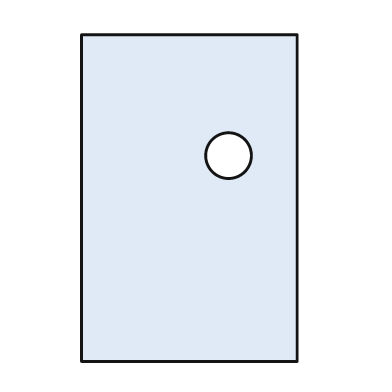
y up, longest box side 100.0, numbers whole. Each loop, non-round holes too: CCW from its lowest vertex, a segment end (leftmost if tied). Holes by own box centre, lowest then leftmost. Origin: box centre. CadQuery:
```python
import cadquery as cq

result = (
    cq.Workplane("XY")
    .moveTo(-33.0, -50.0)
    .lineTo(33.0, -50.0)
    .lineTo(33.0, 50.0)
    .lineTo(-33.0, 50.0)
    .close()
    .moveTo(12.0, 13.0)
    .circle(7.0)
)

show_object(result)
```